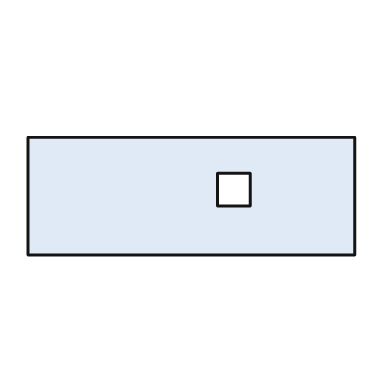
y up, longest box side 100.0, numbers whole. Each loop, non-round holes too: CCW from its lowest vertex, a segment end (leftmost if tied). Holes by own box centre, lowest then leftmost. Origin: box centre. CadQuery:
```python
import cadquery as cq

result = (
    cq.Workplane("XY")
    .moveTo(-50.0, -18.0)
    .lineTo(50.0, -18.0)
    .lineTo(50.0, 18.0)
    .lineTo(-50.0, 18.0)
    .close()
    .moveTo(8.0, -3.0)
    .lineTo(18.0, -3.0)
    .lineTo(18.0, 7.0)
    .lineTo(8.0, 7.0)
    .close()
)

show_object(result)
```